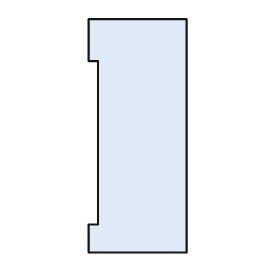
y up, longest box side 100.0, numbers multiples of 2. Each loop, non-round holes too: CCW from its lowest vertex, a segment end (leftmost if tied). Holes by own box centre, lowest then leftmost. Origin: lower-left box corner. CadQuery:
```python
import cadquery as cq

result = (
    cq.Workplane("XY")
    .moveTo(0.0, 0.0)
    .lineTo(42.0, 0.0)
    .lineTo(42.0, 100.0)
    .lineTo(0.0, 100.0)
    .lineTo(0.0, 82.0)
    .lineTo(4.0, 82.0)
    .lineTo(4.0, 12.0)
    .lineTo(0.0, 12.0)
    .close()
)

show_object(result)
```